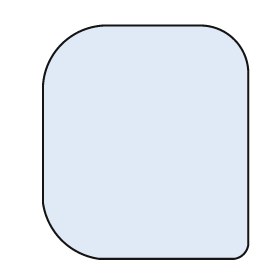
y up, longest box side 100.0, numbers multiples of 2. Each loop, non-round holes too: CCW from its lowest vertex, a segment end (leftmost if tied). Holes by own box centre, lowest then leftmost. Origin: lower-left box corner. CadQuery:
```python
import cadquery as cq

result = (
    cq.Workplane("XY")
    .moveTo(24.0, 0.0)
    .lineTo(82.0, 0.0)
    .threePointArc((86.0, 2.0), (88.0, 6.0))
    .lineTo(88.0, 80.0)
    .threePointArc((82.0, 94.0), (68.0, 100.0))
    .lineTo(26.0, 100.0)
    .threePointArc((8.0, 92.0), (0.0, 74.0))
    .lineTo(0.0, 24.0)
    .threePointArc((8.0, 8.0), (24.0, 0.0))
    .close()
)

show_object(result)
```